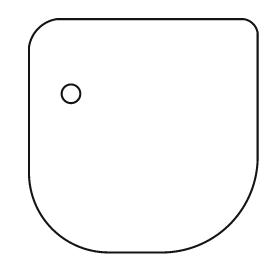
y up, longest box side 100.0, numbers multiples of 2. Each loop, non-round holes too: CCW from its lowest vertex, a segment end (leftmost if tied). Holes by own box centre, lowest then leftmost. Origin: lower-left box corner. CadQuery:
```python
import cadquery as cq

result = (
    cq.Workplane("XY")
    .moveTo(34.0, 0.0)
    .lineTo(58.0, 0.0)
    .threePointArc((86.0, 12.0), (98.0, 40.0))
    .lineTo(98.0, 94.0)
    .threePointArc((96.0, 98.0), (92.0, 100.0))
    .lineTo(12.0, 100.0)
    .threePointArc((4.0, 96.0), (0.0, 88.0))
    .lineTo(0.0, 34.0)
    .threePointArc((10.0, 10.0), (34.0, 0.0))
    .close()
    .moveTo(18.0, 68.0)
    .circle(4.0)
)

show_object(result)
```